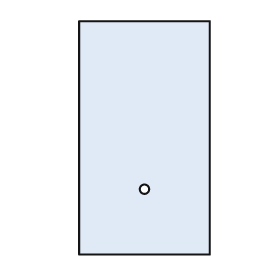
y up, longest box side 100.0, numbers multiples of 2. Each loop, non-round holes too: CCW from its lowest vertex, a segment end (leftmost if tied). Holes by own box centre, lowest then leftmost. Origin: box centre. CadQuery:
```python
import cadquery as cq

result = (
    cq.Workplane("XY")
    .moveTo(-28.0, -50.0)
    .lineTo(28.0, -50.0)
    .lineTo(28.0, 50.0)
    .lineTo(-28.0, 50.0)
    .close()
    .moveTo(0.0, -22.0)
    .circle(2.0)
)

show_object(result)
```